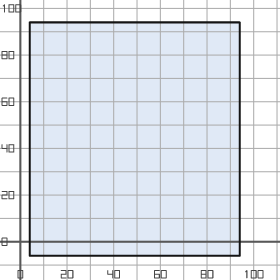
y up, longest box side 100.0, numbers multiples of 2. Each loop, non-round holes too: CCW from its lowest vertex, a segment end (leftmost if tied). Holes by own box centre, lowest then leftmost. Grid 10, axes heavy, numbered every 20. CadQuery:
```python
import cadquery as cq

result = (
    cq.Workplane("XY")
    .moveTo(4.0, -6.0)
    .lineTo(94.0, -6.0)
    .lineTo(94.0, 94.0)
    .lineTo(4.0, 94.0)
    .close()
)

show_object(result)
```